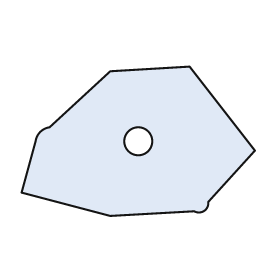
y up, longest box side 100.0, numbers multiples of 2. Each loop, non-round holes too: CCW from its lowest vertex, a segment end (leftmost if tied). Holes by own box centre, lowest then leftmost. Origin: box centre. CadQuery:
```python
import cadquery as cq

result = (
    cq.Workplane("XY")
    .moveTo(-12.0, -32.0)
    .lineTo(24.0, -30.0)
    .threePointArc((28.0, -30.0), (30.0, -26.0))
    .lineTo(50.0, -4.0)
    .lineTo(22.0, 32.0)
    .lineTo(-12.0, 30.0)
    .lineTo(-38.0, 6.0)
    .threePointArc((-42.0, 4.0), (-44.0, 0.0))
    .lineTo(-50.0, -22.0)
    .close()
    .moveTo(0.0, 0.0)
    .circle(6.0)
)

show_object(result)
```